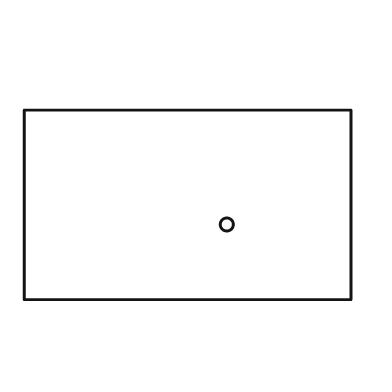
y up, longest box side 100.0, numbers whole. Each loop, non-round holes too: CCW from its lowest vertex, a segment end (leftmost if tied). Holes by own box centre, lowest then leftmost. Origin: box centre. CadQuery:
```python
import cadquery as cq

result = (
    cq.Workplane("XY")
    .moveTo(-50.0, -29.0)
    .lineTo(50.0, -29.0)
    .lineTo(50.0, 29.0)
    .lineTo(-50.0, 29.0)
    .close()
    .moveTo(12.0, -6.0)
    .circle(2.0)
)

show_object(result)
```